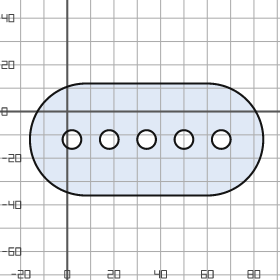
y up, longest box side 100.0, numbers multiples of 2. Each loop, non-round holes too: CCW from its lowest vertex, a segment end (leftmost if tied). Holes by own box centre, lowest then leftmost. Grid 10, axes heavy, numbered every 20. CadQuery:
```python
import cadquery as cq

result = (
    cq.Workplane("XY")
    .moveTo(8.0, -36.0)
    .lineTo(60.0, -36.0)
    .threePointArc((84.0, -12.0), (60.0, 12.0))
    .lineTo(8.0, 12.0)
    .threePointArc((-16.0, -12.0), (8.0, -36.0))
    .close()
    .moveTo(2.0, -12.0)
    .circle(4.0)
    .moveTo(18.0, -12.0)
    .circle(4.0)
    .moveTo(34.0, -12.0)
    .circle(4.0)
    .moveTo(50.0, -12.0)
    .circle(4.0)
    .moveTo(66.0, -12.0)
    .circle(4.0)
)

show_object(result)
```